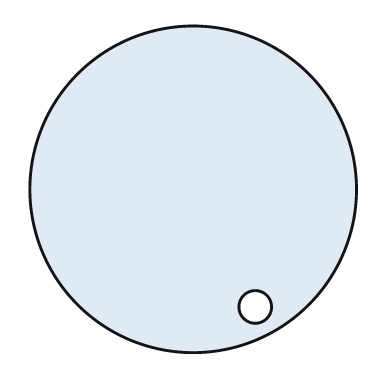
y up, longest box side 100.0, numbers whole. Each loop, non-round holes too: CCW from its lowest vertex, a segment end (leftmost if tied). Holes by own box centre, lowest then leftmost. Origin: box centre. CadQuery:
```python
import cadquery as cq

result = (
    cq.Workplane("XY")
    .moveTo(0.0, 0.0)
    .circle(50.0)
    .moveTo(19.0, -36.0)
    .circle(5.0)
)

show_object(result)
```